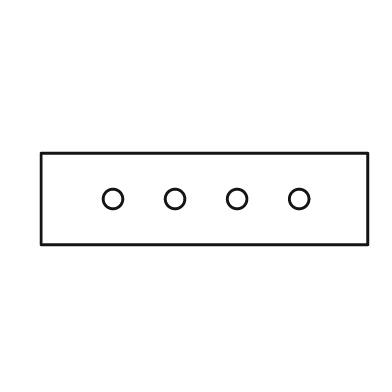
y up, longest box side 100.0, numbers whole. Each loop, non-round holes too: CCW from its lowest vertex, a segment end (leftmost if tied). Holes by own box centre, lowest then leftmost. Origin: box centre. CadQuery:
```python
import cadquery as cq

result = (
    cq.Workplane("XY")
    .moveTo(-50.0, -14.0)
    .lineTo(50.0, -14.0)
    .lineTo(50.0, 14.0)
    .lineTo(-50.0, 14.0)
    .close()
    .moveTo(-28.0, 0.0)
    .circle(3.0)
    .moveTo(-9.0, 0.0)
    .circle(3.0)
    .moveTo(10.0, 0.0)
    .circle(3.0)
    .moveTo(29.0, 0.0)
    .circle(3.0)
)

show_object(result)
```